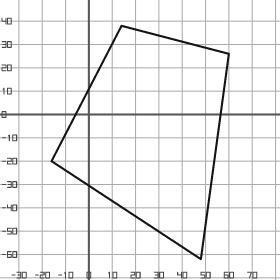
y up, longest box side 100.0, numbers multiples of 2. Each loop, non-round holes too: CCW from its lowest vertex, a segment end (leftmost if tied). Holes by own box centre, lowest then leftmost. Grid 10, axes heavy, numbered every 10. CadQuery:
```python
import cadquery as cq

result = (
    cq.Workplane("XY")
    .moveTo(48.0, -62.0)
    .lineTo(60.0, 26.0)
    .lineTo(14.0, 38.0)
    .lineTo(-16.0, -20.0)
    .close()
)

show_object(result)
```